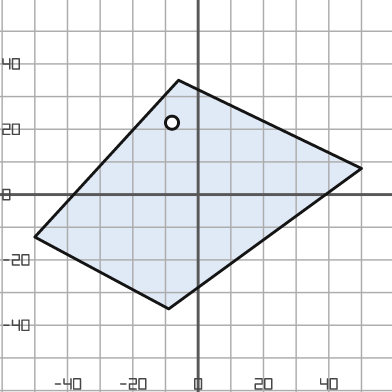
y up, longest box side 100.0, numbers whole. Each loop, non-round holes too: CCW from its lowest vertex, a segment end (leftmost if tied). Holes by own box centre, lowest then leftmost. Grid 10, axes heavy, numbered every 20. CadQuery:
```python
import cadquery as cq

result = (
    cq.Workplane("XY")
    .moveTo(-9.0, -35.0)
    .lineTo(50.0, 8.0)
    .lineTo(-6.0, 35.0)
    .lineTo(-50.0, -13.0)
    .close()
    .moveTo(-8.0, 22.0)
    .circle(2.0)
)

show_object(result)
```